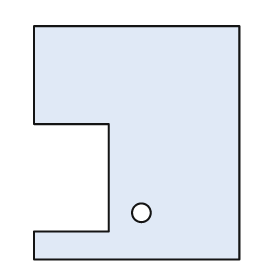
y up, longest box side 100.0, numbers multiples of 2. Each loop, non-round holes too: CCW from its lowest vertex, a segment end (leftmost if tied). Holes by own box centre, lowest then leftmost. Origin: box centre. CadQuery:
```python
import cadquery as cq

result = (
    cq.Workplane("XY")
    .moveTo(-44.0, -50.0)
    .lineTo(44.0, -50.0)
    .lineTo(44.0, 50.0)
    .lineTo(-44.0, 50.0)
    .lineTo(-44.0, 8.0)
    .lineTo(-12.0, 8.0)
    .lineTo(-12.0, -38.0)
    .lineTo(-44.0, -38.0)
    .close()
    .moveTo(2.0, -30.0)
    .circle(4.0)
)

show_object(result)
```